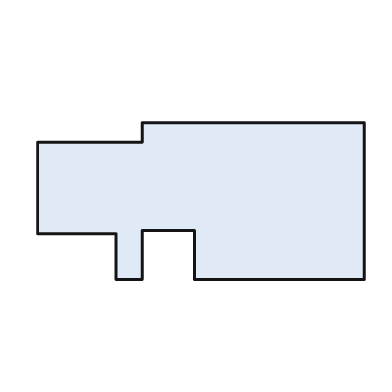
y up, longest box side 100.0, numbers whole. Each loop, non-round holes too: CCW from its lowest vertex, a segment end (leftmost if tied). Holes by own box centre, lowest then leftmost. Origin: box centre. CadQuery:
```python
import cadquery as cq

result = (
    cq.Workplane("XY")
    .moveTo(-26.0, -24.0)
    .lineTo(-18.0, -24.0)
    .lineTo(-18.0, -9.0)
    .lineTo(-2.0, -9.0)
    .lineTo(-2.0, -24.0)
    .lineTo(50.0, -24.0)
    .lineTo(50.0, 24.0)
    .lineTo(-18.0, 24.0)
    .lineTo(-18.0, 18.0)
    .lineTo(-50.0, 18.0)
    .lineTo(-50.0, -10.0)
    .lineTo(-26.0, -10.0)
    .close()
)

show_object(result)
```